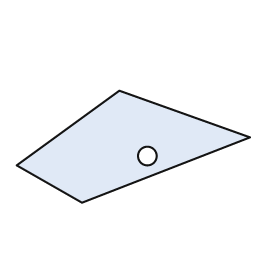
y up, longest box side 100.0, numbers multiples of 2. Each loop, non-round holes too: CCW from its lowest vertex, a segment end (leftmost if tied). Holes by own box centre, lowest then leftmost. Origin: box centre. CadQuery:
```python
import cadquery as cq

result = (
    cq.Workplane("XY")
    .moveTo(-22.0, -24.0)
    .lineTo(50.0, 4.0)
    .lineTo(-6.0, 24.0)
    .lineTo(-50.0, -8.0)
    .close()
    .moveTo(6.0, -4.0)
    .circle(4.0)
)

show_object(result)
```